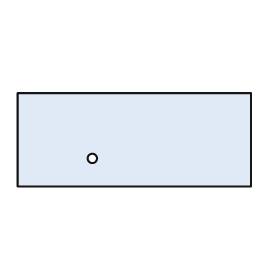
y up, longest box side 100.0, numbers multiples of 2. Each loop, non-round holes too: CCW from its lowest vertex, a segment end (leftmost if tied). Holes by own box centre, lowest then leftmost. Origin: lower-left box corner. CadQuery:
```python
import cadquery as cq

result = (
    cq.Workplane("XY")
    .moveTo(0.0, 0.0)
    .lineTo(100.0, 0.0)
    .lineTo(100.0, 40.0)
    .lineTo(0.0, 40.0)
    .close()
    .moveTo(32.0, 12.0)
    .circle(2.0)
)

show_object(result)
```